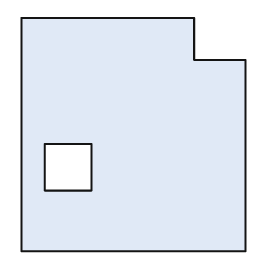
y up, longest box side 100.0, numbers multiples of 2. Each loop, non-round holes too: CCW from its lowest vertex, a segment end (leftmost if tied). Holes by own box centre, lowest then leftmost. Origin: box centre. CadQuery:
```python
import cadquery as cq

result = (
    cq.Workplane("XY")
    .moveTo(-48.0, -50.0)
    .lineTo(48.0, -50.0)
    .lineTo(48.0, 32.0)
    .lineTo(26.0, 32.0)
    .lineTo(26.0, 50.0)
    .lineTo(-48.0, 50.0)
    .close()
    .moveTo(-38.0, -24.0)
    .lineTo(-18.0, -24.0)
    .lineTo(-18.0, -4.0)
    .lineTo(-38.0, -4.0)
    .close()
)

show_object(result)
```